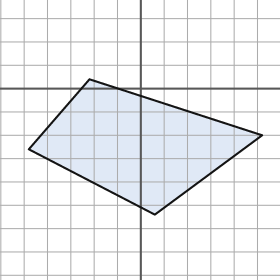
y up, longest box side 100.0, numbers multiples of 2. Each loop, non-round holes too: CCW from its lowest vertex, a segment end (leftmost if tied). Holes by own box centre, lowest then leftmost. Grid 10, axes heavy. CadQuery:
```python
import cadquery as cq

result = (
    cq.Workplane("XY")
    .moveTo(6.0, -54.0)
    .lineTo(52.0, -20.0)
    .lineTo(-22.0, 4.0)
    .lineTo(-48.0, -26.0)
    .close()
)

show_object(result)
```